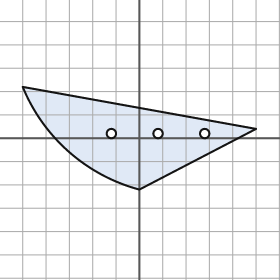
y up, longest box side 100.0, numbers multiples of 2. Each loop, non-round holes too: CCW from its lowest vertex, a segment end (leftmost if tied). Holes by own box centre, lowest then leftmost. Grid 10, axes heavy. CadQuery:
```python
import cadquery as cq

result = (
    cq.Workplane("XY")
    .moveTo(0.0, -22.0)
    .lineTo(50.0, 4.0)
    .lineTo(-50.0, 22.0)
    .threePointArc((-30.0, -6.0), (0.0, -22.0))
    .close()
    .moveTo(-12.0, 2.0)
    .circle(2.0)
    .moveTo(8.0, 2.0)
    .circle(2.0)
    .moveTo(28.0, 2.0)
    .circle(2.0)
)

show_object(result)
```